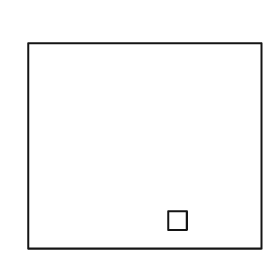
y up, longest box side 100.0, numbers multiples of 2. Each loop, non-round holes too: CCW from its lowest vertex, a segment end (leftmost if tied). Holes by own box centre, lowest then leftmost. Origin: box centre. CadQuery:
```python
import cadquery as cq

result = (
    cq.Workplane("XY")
    .moveTo(-50.0, -44.0)
    .lineTo(50.0, -44.0)
    .lineTo(50.0, 44.0)
    .lineTo(-50.0, 44.0)
    .close()
    .moveTo(10.0, -36.0)
    .lineTo(18.0, -36.0)
    .lineTo(18.0, -28.0)
    .lineTo(10.0, -28.0)
    .close()
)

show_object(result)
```